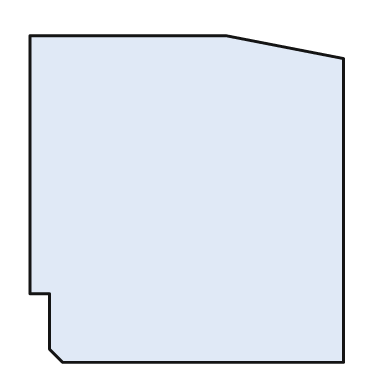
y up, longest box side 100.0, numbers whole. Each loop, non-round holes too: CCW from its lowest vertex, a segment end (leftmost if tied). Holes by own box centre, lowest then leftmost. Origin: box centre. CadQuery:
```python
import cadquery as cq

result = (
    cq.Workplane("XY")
    .moveTo(-38.0, -50.0)
    .lineTo(48.0, -50.0)
    .lineTo(48.0, 43.0)
    .lineTo(12.0, 50.0)
    .lineTo(-48.0, 50.0)
    .lineTo(-48.0, -29.0)
    .lineTo(-42.0, -29.0)
    .lineTo(-42.0, -46.0)
    .close()
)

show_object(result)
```